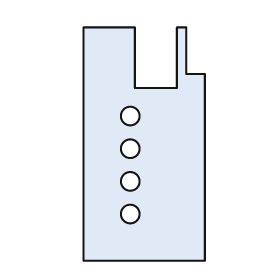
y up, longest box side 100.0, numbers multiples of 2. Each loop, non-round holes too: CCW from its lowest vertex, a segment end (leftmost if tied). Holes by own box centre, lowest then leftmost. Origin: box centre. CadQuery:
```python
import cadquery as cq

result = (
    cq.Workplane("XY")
    .moveTo(-26.0, -50.0)
    .lineTo(26.0, -50.0)
    .lineTo(26.0, 30.0)
    .lineTo(18.0, 30.0)
    .lineTo(18.0, 50.0)
    .lineTo(14.0, 50.0)
    .lineTo(14.0, 24.0)
    .lineTo(-4.0, 24.0)
    .lineTo(-4.0, 50.0)
    .lineTo(-26.0, 50.0)
    .close()
    .moveTo(-6.0, -30.0)
    .circle(4.0)
    .moveTo(-6.0, -16.0)
    .circle(4.0)
    .moveTo(-6.0, -2.0)
    .circle(4.0)
    .moveTo(-6.0, 12.0)
    .circle(4.0)
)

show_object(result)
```